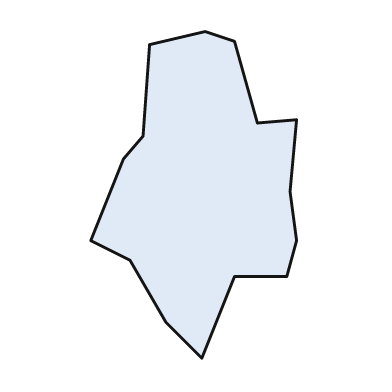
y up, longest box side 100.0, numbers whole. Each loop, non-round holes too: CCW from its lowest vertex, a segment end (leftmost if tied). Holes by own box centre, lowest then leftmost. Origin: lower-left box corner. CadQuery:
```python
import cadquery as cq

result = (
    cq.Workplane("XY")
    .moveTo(34.0, 0.0)
    .lineTo(44.0, 25.0)
    .lineTo(60.0, 25.0)
    .lineTo(63.0, 36.0)
    .lineTo(61.0, 51.0)
    .lineTo(63.0, 73.0)
    .lineTo(51.0, 72.0)
    .lineTo(44.0, 97.0)
    .lineTo(35.0, 100.0)
    .lineTo(18.0, 96.0)
    .lineTo(16.0, 68.0)
    .lineTo(10.0, 61.0)
    .lineTo(0.0, 36.0)
    .lineTo(12.0, 30.0)
    .lineTo(23.0, 11.0)
    .close()
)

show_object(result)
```